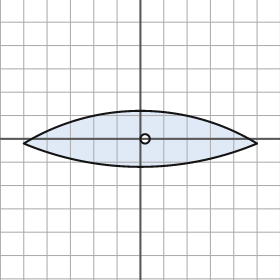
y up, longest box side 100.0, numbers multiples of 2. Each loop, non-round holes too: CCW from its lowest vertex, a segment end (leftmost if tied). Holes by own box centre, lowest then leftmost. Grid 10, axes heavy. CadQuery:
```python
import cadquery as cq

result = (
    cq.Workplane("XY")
    .moveTo(-50.0, -2.0)
    .threePointArc((0.0, -12.0), (50.0, -2.0))
    .threePointArc((0.0, 12.0), (-50.0, -2.0))
    .close()
    .moveTo(2.0, 0.0)
    .circle(2.0)
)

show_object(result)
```